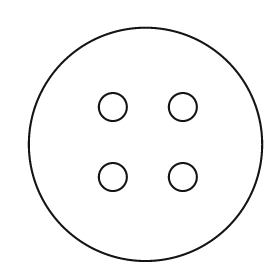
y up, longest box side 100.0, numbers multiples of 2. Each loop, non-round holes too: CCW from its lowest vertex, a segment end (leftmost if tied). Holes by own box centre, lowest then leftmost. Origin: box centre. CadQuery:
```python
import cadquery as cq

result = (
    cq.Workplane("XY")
    .moveTo(0.0, 0.0)
    .circle(50.0)
    .moveTo(-14.0, -14.0)
    .circle(6.0)
    .moveTo(16.0, -14.0)
    .circle(6.0)
    .moveTo(-14.0, 16.0)
    .circle(6.0)
    .moveTo(16.0, 16.0)
    .circle(6.0)
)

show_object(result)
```